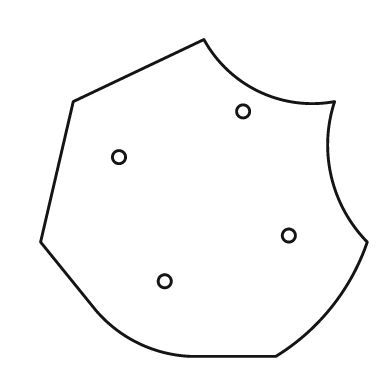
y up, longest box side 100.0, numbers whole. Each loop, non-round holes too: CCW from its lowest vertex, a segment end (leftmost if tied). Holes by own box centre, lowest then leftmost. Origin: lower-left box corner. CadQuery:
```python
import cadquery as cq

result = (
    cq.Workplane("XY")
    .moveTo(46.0, 0.0)
    .lineTo(72.0, 0.0)
    .threePointArc((89.0, 15.0), (100.0, 35.0))
    .threePointArc((89.0, 55.0), (90.0, 78.0))
    .threePointArc((67.0, 81.0), (50.0, 97.0))
    .lineTo(10.0, 78.0)
    .lineTo(0.0, 35.0)
    .lineTo(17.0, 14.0)
    .threePointArc((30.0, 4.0), (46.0, 0.0))
    .close()
    .moveTo(38.0, 23.0)
    .circle(2.0)
    .moveTo(76.0, 37.0)
    .circle(2.0)
    .moveTo(24.0, 61.0)
    .circle(2.0)
    .moveTo(62.0, 75.0)
    .circle(2.0)
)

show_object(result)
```